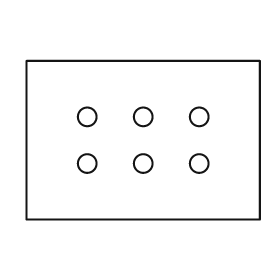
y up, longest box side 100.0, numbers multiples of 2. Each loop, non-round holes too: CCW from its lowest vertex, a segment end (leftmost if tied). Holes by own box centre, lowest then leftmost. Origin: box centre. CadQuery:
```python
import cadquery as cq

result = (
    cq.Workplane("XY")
    .moveTo(-50.0, -34.0)
    .lineTo(50.0, -34.0)
    .lineTo(50.0, 34.0)
    .lineTo(-50.0, 34.0)
    .close()
    .moveTo(-24.0, -10.0)
    .circle(4.0)
    .moveTo(0.0, -10.0)
    .circle(4.0)
    .moveTo(24.0, -10.0)
    .circle(4.0)
    .moveTo(-24.0, 10.0)
    .circle(4.0)
    .moveTo(0.0, 10.0)
    .circle(4.0)
    .moveTo(24.0, 10.0)
    .circle(4.0)
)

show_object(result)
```